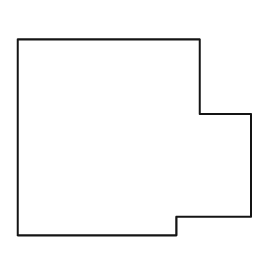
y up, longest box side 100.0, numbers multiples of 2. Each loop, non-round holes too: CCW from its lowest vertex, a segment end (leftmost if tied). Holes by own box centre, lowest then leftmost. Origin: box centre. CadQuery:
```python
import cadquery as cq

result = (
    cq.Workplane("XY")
    .moveTo(-50.0, -42.0)
    .lineTo(18.0, -42.0)
    .lineTo(18.0, -34.0)
    .lineTo(50.0, -34.0)
    .lineTo(50.0, 10.0)
    .lineTo(28.0, 10.0)
    .lineTo(28.0, 42.0)
    .lineTo(-50.0, 42.0)
    .close()
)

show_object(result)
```